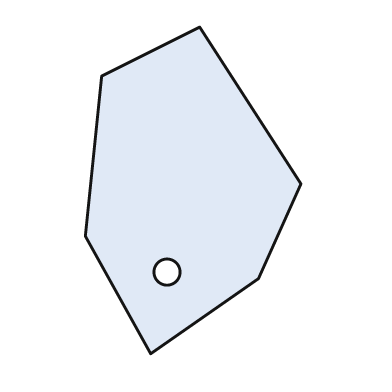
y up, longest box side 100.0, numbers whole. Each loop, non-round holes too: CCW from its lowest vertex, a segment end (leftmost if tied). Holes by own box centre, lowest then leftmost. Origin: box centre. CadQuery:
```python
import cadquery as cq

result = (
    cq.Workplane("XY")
    .moveTo(-13.0, -50.0)
    .lineTo(20.0, -27.0)
    .lineTo(33.0, 2.0)
    .lineTo(2.0, 50.0)
    .lineTo(-28.0, 35.0)
    .lineTo(-33.0, -14.0)
    .close()
    .moveTo(-8.0, -25.0)
    .circle(4.0)
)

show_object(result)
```